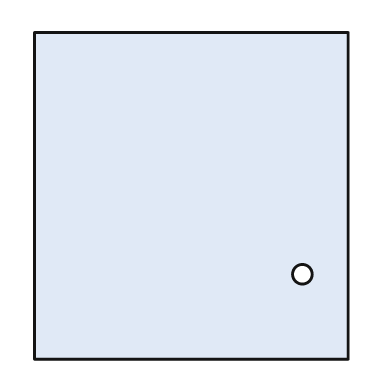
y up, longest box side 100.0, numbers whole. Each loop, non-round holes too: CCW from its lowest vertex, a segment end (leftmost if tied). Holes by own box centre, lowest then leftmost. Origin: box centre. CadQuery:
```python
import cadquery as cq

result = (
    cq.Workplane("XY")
    .moveTo(-48.0, -50.0)
    .lineTo(48.0, -50.0)
    .lineTo(48.0, 50.0)
    .lineTo(-48.0, 50.0)
    .close()
    .moveTo(34.0, -24.0)
    .circle(3.0)
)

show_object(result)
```